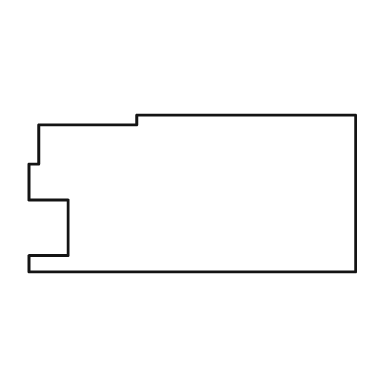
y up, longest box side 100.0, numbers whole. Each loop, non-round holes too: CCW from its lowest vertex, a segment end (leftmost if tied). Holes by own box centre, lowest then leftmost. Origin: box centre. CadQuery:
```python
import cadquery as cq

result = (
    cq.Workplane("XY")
    .moveTo(-50.0, -24.0)
    .lineTo(50.0, -24.0)
    .lineTo(50.0, 24.0)
    .lineTo(-17.0, 24.0)
    .lineTo(-17.0, 21.0)
    .lineTo(-47.0, 21.0)
    .lineTo(-47.0, 9.0)
    .lineTo(-50.0, 9.0)
    .lineTo(-50.0, -2.0)
    .lineTo(-38.0, -2.0)
    .lineTo(-38.0, -19.0)
    .lineTo(-50.0, -19.0)
    .close()
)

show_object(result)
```